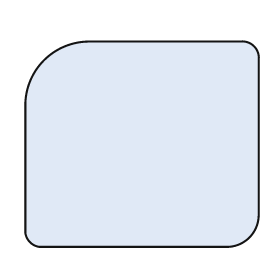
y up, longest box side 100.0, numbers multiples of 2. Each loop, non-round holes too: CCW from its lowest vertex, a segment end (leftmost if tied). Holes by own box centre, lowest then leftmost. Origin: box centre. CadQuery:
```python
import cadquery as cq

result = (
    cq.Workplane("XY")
    .moveTo(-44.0, -44.0)
    .lineTo(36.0, -44.0)
    .threePointArc((46.0, -40.0), (50.0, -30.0))
    .lineTo(50.0, 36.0)
    .threePointArc((48.0, 42.0), (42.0, 44.0))
    .lineTo(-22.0, 44.0)
    .threePointArc((-42.0, 36.0), (-50.0, 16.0))
    .lineTo(-50.0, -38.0)
    .threePointArc((-48.0, -42.0), (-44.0, -44.0))
    .close()
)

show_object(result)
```